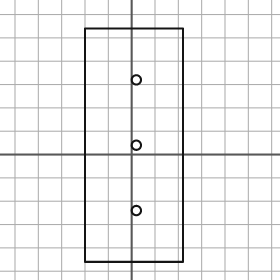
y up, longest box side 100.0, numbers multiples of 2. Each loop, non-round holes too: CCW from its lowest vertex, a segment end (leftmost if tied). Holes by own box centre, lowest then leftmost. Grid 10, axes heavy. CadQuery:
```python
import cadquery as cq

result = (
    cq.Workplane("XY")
    .moveTo(-20.0, -46.0)
    .lineTo(22.0, -46.0)
    .lineTo(22.0, 54.0)
    .lineTo(-20.0, 54.0)
    .close()
    .moveTo(2.0, -24.0)
    .circle(2.0)
    .moveTo(2.0, 4.0)
    .circle(2.0)
    .moveTo(2.0, 32.0)
    .circle(2.0)
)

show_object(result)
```